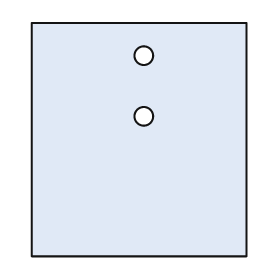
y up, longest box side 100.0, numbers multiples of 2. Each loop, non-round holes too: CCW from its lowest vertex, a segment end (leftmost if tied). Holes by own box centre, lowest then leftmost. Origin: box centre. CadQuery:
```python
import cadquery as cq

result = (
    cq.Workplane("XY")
    .moveTo(-46.0, -50.0)
    .lineTo(46.0, -50.0)
    .lineTo(46.0, 50.0)
    .lineTo(-46.0, 50.0)
    .close()
    .moveTo(2.0, 10.0)
    .circle(4.0)
    .moveTo(2.0, 36.0)
    .circle(4.0)
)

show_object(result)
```